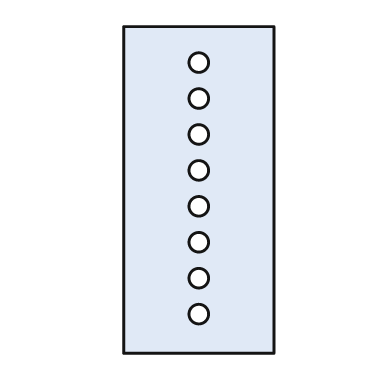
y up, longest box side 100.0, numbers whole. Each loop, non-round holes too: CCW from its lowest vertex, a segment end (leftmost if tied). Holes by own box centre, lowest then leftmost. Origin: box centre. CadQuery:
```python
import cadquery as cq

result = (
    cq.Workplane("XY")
    .moveTo(-23.0, -50.0)
    .lineTo(23.0, -50.0)
    .lineTo(23.0, 50.0)
    .lineTo(-23.0, 50.0)
    .close()
    .moveTo(0.0, -38.0)
    .circle(3.0)
    .moveTo(0.0, -27.0)
    .circle(3.0)
    .moveTo(0.0, -16.0)
    .circle(3.0)
    .moveTo(0.0, -5.0)
    .circle(3.0)
    .moveTo(0.0, 6.0)
    .circle(3.0)
    .moveTo(0.0, 17.0)
    .circle(3.0)
    .moveTo(0.0, 28.0)
    .circle(3.0)
    .moveTo(0.0, 39.0)
    .circle(3.0)
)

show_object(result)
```